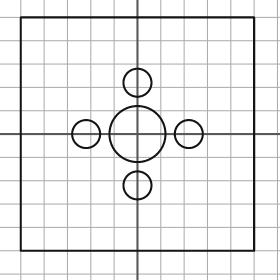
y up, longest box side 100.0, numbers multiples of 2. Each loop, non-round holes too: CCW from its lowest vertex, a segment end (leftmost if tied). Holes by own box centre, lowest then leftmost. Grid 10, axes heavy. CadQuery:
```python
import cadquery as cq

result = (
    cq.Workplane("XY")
    .moveTo(-50.0, -50.0)
    .lineTo(50.0, -50.0)
    .lineTo(50.0, 50.0)
    .lineTo(-50.0, 50.0)
    .close()
    .moveTo(0.0, -22.0)
    .circle(6.0)
    .moveTo(-22.0, 0.0)
    .circle(6.0)
    .moveTo(0.0, 0.0)
    .circle(12.0)
    .moveTo(22.0, 0.0)
    .circle(6.0)
    .moveTo(0.0, 22.0)
    .circle(6.0)
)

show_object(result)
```